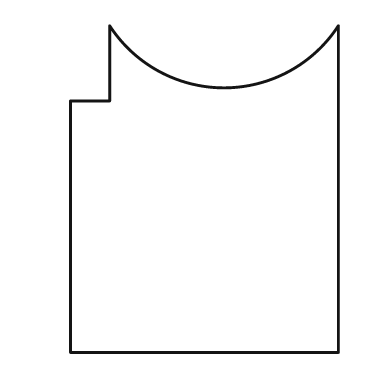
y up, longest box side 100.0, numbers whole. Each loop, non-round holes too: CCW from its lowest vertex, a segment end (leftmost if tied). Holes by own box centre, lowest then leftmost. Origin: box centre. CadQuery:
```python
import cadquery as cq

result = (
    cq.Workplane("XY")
    .moveTo(-41.0, -50.0)
    .lineTo(41.0, -50.0)
    .lineTo(41.0, 50.0)
    .threePointArc((6.0, 31.0), (-29.0, 50.0))
    .lineTo(-29.0, 27.0)
    .lineTo(-41.0, 27.0)
    .close()
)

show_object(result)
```